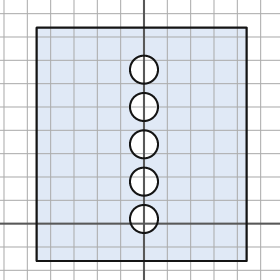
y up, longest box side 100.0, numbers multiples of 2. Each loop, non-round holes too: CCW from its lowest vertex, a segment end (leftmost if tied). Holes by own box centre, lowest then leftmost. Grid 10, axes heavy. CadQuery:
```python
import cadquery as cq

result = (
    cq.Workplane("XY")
    .moveTo(-46.0, -16.0)
    .lineTo(44.0, -16.0)
    .lineTo(44.0, 84.0)
    .lineTo(-46.0, 84.0)
    .close()
    .moveTo(0.0, 2.0)
    .circle(6.0)
    .moveTo(0.0, 18.0)
    .circle(6.0)
    .moveTo(0.0, 34.0)
    .circle(6.0)
    .moveTo(0.0, 50.0)
    .circle(6.0)
    .moveTo(0.0, 66.0)
    .circle(6.0)
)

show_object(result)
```